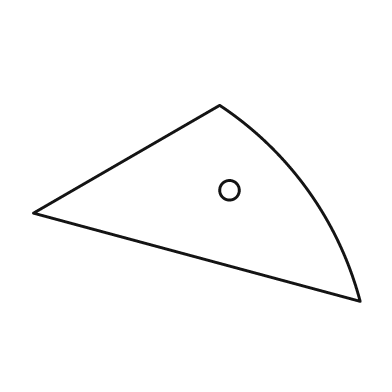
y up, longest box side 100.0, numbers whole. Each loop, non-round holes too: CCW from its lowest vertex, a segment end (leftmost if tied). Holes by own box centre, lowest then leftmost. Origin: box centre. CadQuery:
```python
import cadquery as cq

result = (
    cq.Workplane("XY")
    .moveTo(50.0, -30.0)
    .threePointArc((34.0, 4.0), (7.0, 30.0))
    .lineTo(-50.0, -3.0)
    .close()
    .moveTo(10.0, 4.0)
    .circle(3.0)
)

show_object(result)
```